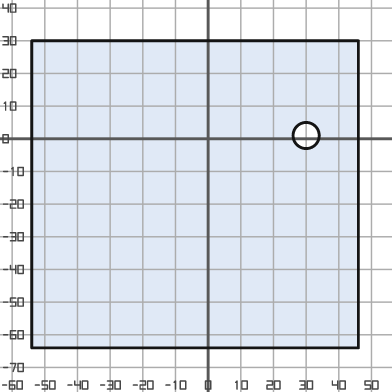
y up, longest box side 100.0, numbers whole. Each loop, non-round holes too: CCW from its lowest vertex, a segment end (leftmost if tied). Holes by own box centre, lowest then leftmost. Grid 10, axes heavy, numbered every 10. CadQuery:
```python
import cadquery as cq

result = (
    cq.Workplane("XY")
    .moveTo(-54.0, -64.0)
    .lineTo(46.0, -64.0)
    .lineTo(46.0, 30.0)
    .lineTo(-54.0, 30.0)
    .close()
    .moveTo(30.0, 1.0)
    .circle(4.0)
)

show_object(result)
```